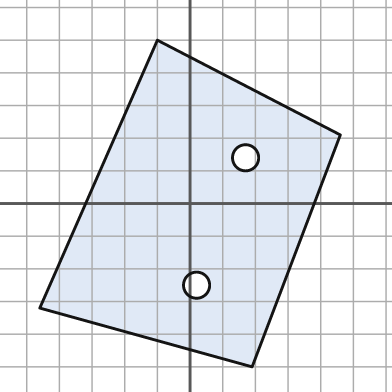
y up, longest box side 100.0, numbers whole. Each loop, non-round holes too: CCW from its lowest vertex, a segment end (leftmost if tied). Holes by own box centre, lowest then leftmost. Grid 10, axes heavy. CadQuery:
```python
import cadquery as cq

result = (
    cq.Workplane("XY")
    .moveTo(19.0, -50.0)
    .lineTo(46.0, 21.0)
    .lineTo(-10.0, 50.0)
    .lineTo(-46.0, -32.0)
    .close()
    .moveTo(2.0, -25.0)
    .circle(4.0)
    .moveTo(17.0, 14.0)
    .circle(4.0)
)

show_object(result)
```